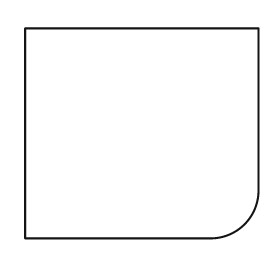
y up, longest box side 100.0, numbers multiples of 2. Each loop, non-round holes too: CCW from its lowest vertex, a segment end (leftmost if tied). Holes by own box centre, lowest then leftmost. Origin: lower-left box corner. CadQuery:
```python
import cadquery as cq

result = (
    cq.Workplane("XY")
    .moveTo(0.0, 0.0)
    .lineTo(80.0, 0.0)
    .threePointArc((94.0, 6.0), (100.0, 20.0))
    .lineTo(100.0, 90.0)
    .lineTo(0.0, 90.0)
    .close()
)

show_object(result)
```